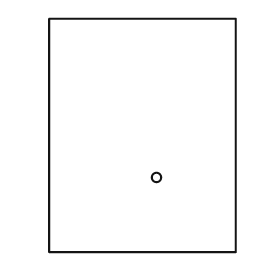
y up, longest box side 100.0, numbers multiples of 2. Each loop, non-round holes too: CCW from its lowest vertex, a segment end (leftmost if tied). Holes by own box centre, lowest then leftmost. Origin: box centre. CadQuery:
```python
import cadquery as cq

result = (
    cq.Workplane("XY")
    .moveTo(-40.0, -50.0)
    .lineTo(40.0, -50.0)
    .lineTo(40.0, 50.0)
    .lineTo(-40.0, 50.0)
    .close()
    .moveTo(6.0, -18.0)
    .circle(2.0)
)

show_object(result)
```